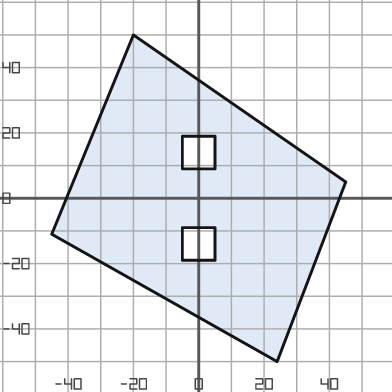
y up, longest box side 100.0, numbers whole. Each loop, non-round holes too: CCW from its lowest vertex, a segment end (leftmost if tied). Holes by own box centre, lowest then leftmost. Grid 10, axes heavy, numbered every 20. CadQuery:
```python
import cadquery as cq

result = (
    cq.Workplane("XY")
    .moveTo(24.0, -50.0)
    .lineTo(45.0, 5.0)
    .lineTo(-20.0, 50.0)
    .lineTo(-45.0, -11.0)
    .close()
    .moveTo(-5.0, -19.0)
    .lineTo(5.0, -19.0)
    .lineTo(5.0, -9.0)
    .lineTo(-5.0, -9.0)
    .close()
    .moveTo(-5.0, 9.0)
    .lineTo(5.0, 9.0)
    .lineTo(5.0, 19.0)
    .lineTo(-5.0, 19.0)
    .close()
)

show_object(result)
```